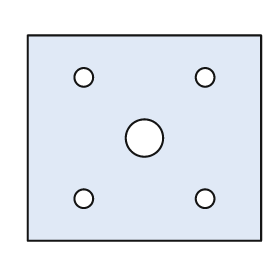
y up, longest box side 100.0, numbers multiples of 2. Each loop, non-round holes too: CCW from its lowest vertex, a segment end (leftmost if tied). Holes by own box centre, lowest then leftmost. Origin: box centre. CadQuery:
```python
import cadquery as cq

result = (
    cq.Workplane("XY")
    .moveTo(-50.0, -44.0)
    .lineTo(50.0, -44.0)
    .lineTo(50.0, 44.0)
    .lineTo(-50.0, 44.0)
    .close()
    .moveTo(-26.0, -26.0)
    .circle(4.0)
    .moveTo(26.0, -26.0)
    .circle(4.0)
    .moveTo(0.0, 0.0)
    .circle(8.0)
    .moveTo(-26.0, 26.0)
    .circle(4.0)
    .moveTo(26.0, 26.0)
    .circle(4.0)
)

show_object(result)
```